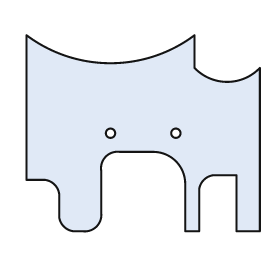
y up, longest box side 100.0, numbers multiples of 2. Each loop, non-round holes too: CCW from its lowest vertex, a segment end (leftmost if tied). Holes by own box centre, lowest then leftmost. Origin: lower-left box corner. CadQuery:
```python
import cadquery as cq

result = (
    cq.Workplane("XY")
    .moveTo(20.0, 0.0)
    .lineTo(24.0, 0.0)
    .threePointArc((30.0, 2.0), (32.0, 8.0))
    .lineTo(32.0, 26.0)
    .threePointArc((34.0, 32.0), (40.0, 34.0))
    .lineTo(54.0, 34.0)
    .threePointArc((64.0, 30.0), (68.0, 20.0))
    .lineTo(68.0, 0.0)
    .lineTo(74.0, 0.0)
    .lineTo(74.0, 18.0)
    .threePointArc((76.0, 22.0), (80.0, 24.0))
    .lineTo(90.0, 24.0)
    .lineTo(90.0, 0.0)
    .lineTo(100.0, 0.0)
    .lineTo(100.0, 70.0)
    .threePointArc((86.0, 64.0), (72.0, 70.0))
    .lineTo(72.0, 84.0)
    .threePointArc((36.0, 72.0), (0.0, 84.0))
    .lineTo(0.0, 22.0)
    .lineTo(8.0, 22.0)
    .threePointArc((12.0, 20.0), (14.0, 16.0))
    .lineTo(14.0, 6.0)
    .threePointArc((16.0, 2.0), (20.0, 0.0))
    .close()
    .moveTo(36.0, 42.0)
    .circle(2.0)
    .moveTo(64.0, 42.0)
    .circle(2.0)
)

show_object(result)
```